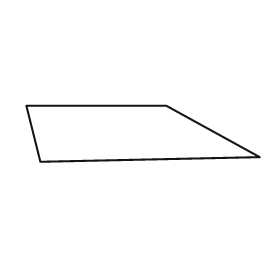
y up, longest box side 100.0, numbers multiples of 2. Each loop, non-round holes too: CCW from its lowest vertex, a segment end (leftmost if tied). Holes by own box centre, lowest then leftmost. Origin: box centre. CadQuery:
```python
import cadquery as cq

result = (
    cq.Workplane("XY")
    .moveTo(-44.0, -12.0)
    .lineTo(50.0, -10.0)
    .lineTo(10.0, 12.0)
    .lineTo(-50.0, 12.0)
    .close()
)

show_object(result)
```